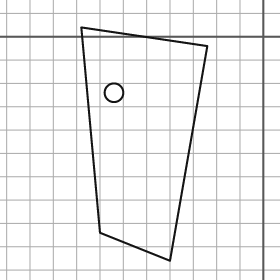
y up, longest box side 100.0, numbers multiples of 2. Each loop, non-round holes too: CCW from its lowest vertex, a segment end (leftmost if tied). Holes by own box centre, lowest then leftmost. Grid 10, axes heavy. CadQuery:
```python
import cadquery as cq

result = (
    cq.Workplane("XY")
    .moveTo(-40.0, -96.0)
    .lineTo(-24.0, -4.0)
    .lineTo(-78.0, 4.0)
    .lineTo(-70.0, -84.0)
    .close()
    .moveTo(-64.0, -24.0)
    .circle(4.0)
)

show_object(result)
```